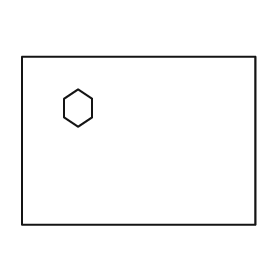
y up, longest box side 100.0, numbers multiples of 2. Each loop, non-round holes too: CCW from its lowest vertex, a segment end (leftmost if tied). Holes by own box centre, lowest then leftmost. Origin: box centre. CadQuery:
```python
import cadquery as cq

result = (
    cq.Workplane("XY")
    .moveTo(-50.0, -36.0)
    .lineTo(50.0, -36.0)
    .lineTo(50.0, 36.0)
    .lineTo(-50.0, 36.0)
    .close()
    .moveTo(-26.0, 6.0)
    .lineTo(-20.0, 10.0)
    .lineTo(-20.0, 18.0)
    .lineTo(-26.0, 22.0)
    .lineTo(-32.0, 18.0)
    .lineTo(-32.0, 10.0)
    .close()
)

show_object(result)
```